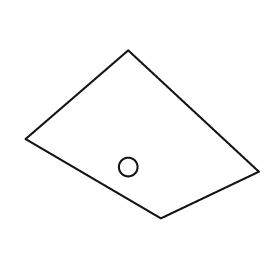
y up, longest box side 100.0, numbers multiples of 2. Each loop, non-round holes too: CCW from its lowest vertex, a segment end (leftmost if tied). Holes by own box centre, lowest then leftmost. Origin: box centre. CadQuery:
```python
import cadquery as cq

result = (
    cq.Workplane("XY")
    .moveTo(8.0, -36.0)
    .lineTo(50.0, -16.0)
    .lineTo(-6.0, 36.0)
    .lineTo(-50.0, -2.0)
    .close()
    .moveTo(-6.0, -14.0)
    .circle(4.0)
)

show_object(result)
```